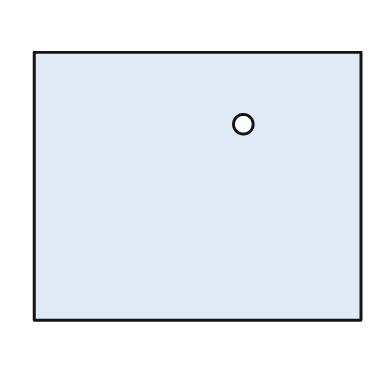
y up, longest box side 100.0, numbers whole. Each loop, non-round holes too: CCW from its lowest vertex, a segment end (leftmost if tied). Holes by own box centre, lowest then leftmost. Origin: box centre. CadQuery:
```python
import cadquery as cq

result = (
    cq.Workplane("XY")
    .moveTo(-50.0, -41.0)
    .lineTo(50.0, -41.0)
    .lineTo(50.0, 41.0)
    .lineTo(-50.0, 41.0)
    .close()
    .moveTo(14.0, 19.0)
    .circle(3.0)
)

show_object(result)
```